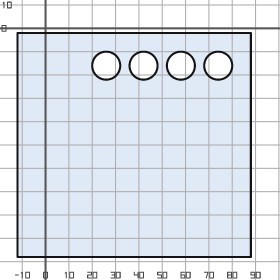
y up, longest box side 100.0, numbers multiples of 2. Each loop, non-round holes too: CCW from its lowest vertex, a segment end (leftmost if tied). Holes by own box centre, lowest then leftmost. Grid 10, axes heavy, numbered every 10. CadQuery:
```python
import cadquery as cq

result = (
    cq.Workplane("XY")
    .moveTo(-12.0, -98.0)
    .lineTo(88.0, -98.0)
    .lineTo(88.0, -2.0)
    .lineTo(-12.0, -2.0)
    .close()
    .moveTo(26.0, -16.0)
    .circle(6.0)
    .moveTo(42.0, -16.0)
    .circle(6.0)
    .moveTo(58.0, -16.0)
    .circle(6.0)
    .moveTo(74.0, -16.0)
    .circle(6.0)
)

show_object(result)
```